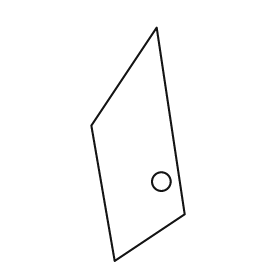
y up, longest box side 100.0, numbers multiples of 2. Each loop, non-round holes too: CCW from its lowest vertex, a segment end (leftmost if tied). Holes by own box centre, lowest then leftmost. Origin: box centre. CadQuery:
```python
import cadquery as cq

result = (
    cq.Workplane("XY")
    .moveTo(-10.0, -50.0)
    .lineTo(20.0, -30.0)
    .lineTo(8.0, 50.0)
    .lineTo(-20.0, 8.0)
    .close()
    .moveTo(10.0, -16.0)
    .circle(4.0)
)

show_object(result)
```